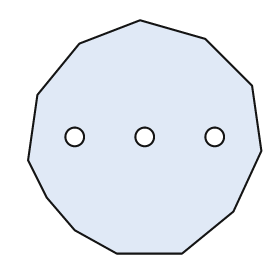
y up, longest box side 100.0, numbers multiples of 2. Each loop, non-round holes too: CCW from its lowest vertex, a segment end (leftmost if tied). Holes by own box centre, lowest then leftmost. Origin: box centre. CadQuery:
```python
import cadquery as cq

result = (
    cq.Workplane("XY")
    .moveTo(-12.0, -50.0)
    .lineTo(16.0, -50.0)
    .lineTo(38.0, -32.0)
    .lineTo(50.0, -6.0)
    .lineTo(46.0, 22.0)
    .lineTo(26.0, 42.0)
    .lineTo(-2.0, 50.0)
    .lineTo(-28.0, 40.0)
    .lineTo(-46.0, 18.0)
    .lineTo(-50.0, -10.0)
    .lineTo(-42.0, -26.0)
    .lineTo(-30.0, -40.0)
    .close()
    .moveTo(-30.0, 0.0)
    .circle(4.0)
    .moveTo(0.0, 0.0)
    .circle(4.0)
    .moveTo(30.0, 0.0)
    .circle(4.0)
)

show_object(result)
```